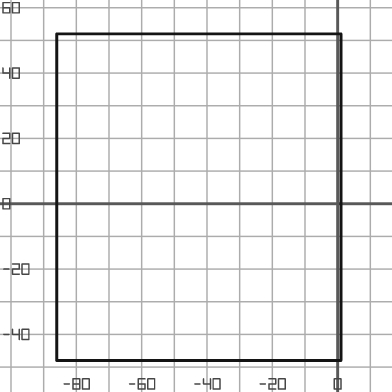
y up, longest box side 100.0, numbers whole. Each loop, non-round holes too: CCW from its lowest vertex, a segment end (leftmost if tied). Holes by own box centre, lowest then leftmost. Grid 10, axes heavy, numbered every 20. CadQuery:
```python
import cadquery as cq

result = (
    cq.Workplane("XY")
    .moveTo(-86.0, -48.0)
    .lineTo(1.0, -48.0)
    .lineTo(1.0, 52.0)
    .lineTo(-86.0, 52.0)
    .close()
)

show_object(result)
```